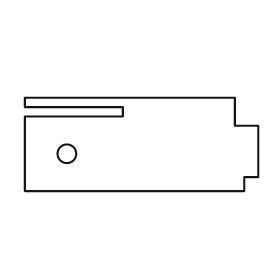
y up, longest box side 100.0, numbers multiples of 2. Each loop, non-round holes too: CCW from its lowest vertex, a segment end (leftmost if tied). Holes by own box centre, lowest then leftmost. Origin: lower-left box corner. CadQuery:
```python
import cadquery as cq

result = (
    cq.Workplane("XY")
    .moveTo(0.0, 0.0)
    .lineTo(94.0, 0.0)
    .lineTo(94.0, 6.0)
    .lineTo(100.0, 6.0)
    .lineTo(100.0, 28.0)
    .lineTo(90.0, 28.0)
    .lineTo(90.0, 40.0)
    .lineTo(0.0, 40.0)
    .lineTo(0.0, 36.0)
    .lineTo(42.0, 36.0)
    .lineTo(42.0, 32.0)
    .lineTo(0.0, 32.0)
    .close()
    .moveTo(18.0, 16.0)
    .circle(4.0)
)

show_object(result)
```